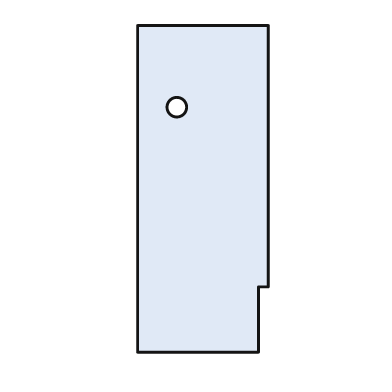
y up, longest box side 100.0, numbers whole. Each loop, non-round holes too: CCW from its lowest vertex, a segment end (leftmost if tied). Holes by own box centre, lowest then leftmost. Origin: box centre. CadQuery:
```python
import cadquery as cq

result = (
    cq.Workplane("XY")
    .moveTo(-20.0, -50.0)
    .lineTo(17.0, -50.0)
    .lineTo(17.0, -30.0)
    .lineTo(20.0, -30.0)
    .lineTo(20.0, 50.0)
    .lineTo(-20.0, 50.0)
    .close()
    .moveTo(-8.0, 25.0)
    .circle(3.0)
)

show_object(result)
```